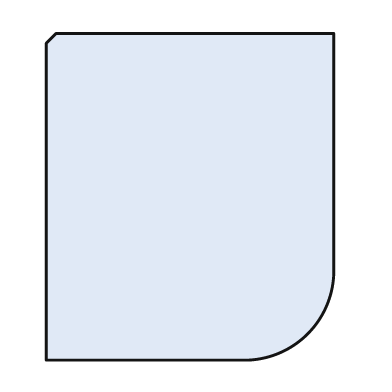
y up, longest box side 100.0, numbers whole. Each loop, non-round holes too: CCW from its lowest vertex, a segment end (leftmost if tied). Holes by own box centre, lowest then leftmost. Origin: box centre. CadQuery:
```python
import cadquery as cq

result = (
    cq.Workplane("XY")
    .moveTo(-44.0, -50.0)
    .lineTo(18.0, -50.0)
    .threePointArc((36.0, -42.0), (44.0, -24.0))
    .lineTo(44.0, 50.0)
    .lineTo(-41.0, 50.0)
    .lineTo(-44.0, 47.0)
    .close()
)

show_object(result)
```